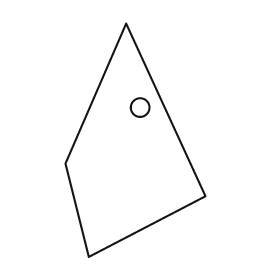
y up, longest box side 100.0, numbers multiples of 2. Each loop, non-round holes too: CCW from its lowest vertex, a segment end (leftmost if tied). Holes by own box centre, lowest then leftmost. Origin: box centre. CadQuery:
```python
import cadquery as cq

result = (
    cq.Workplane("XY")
    .moveTo(-20.0, -50.0)
    .lineTo(30.0, -24.0)
    .lineTo(-4.0, 50.0)
    .lineTo(-30.0, -10.0)
    .close()
    .moveTo(2.0, 14.0)
    .circle(4.0)
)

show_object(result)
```